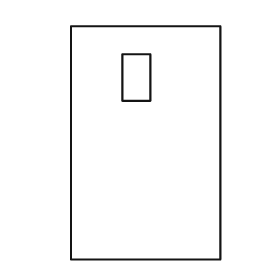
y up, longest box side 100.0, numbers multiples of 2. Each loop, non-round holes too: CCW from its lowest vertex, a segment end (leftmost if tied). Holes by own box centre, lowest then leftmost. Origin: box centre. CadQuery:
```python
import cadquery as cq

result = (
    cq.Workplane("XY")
    .moveTo(-32.0, -50.0)
    .lineTo(32.0, -50.0)
    .lineTo(32.0, 50.0)
    .lineTo(-32.0, 50.0)
    .close()
    .moveTo(-10.0, 18.0)
    .lineTo(2.0, 18.0)
    .lineTo(2.0, 38.0)
    .lineTo(-10.0, 38.0)
    .close()
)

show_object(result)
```